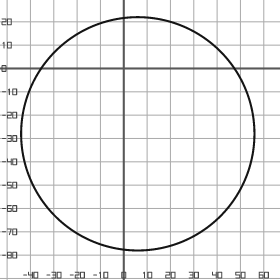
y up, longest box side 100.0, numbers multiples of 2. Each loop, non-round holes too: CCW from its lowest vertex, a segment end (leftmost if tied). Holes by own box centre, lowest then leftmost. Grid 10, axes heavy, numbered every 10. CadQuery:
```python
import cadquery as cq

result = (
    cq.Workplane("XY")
    .moveTo(6.0, -28.0)
    .circle(50.0)
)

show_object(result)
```